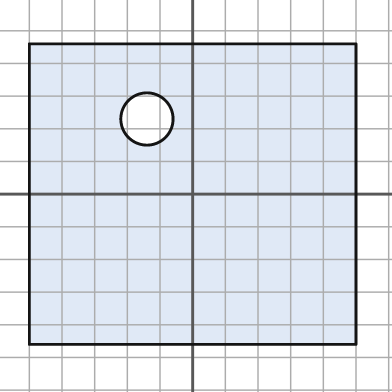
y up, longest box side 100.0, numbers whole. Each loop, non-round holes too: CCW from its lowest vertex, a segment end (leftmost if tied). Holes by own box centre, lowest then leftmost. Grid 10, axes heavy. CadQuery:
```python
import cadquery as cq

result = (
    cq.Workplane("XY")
    .moveTo(-50.0, -46.0)
    .lineTo(50.0, -46.0)
    .lineTo(50.0, 46.0)
    .lineTo(-50.0, 46.0)
    .close()
    .moveTo(-14.0, 23.0)
    .circle(8.0)
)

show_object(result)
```